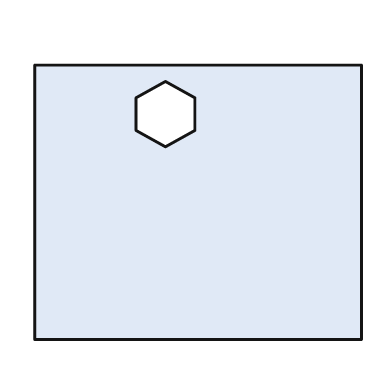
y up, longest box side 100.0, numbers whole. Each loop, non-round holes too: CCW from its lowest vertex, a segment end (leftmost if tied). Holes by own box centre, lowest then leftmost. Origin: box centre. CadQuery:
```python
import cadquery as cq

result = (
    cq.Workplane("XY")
    .moveTo(-50.0, -42.0)
    .lineTo(50.0, -42.0)
    .lineTo(50.0, 42.0)
    .lineTo(-50.0, 42.0)
    .close()
    .moveTo(-10.0, 17.0)
    .lineTo(-1.0, 22.0)
    .lineTo(-1.0, 32.0)
    .lineTo(-10.0, 37.0)
    .lineTo(-19.0, 32.0)
    .lineTo(-19.0, 22.0)
    .close()
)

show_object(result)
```